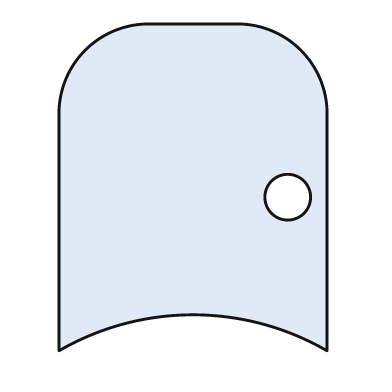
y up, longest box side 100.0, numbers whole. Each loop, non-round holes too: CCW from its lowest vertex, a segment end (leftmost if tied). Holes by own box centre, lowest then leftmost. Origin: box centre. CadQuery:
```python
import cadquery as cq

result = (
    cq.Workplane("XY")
    .moveTo(-41.0, -50.0)
    .threePointArc((0.0, -39.0), (41.0, -50.0))
    .lineTo(41.0, 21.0)
    .threePointArc((33.0, 42.0), (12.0, 50.0))
    .lineTo(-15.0, 50.0)
    .threePointArc((-33.0, 42.0), (-41.0, 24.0))
    .close()
    .moveTo(29.0, -3.0)
    .circle(7.0)
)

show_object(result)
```